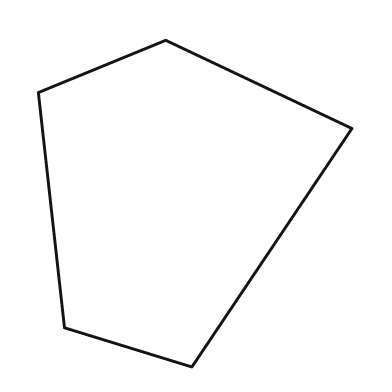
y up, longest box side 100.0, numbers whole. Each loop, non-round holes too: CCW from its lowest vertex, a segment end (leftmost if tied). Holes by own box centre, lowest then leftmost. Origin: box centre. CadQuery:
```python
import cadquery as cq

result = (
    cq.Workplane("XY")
    .moveTo(-1.0, -50.0)
    .lineTo(48.0, 23.0)
    .lineTo(-9.0, 50.0)
    .lineTo(-48.0, 34.0)
    .lineTo(-40.0, -38.0)
    .close()
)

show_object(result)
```